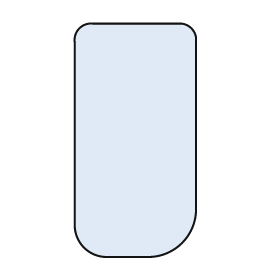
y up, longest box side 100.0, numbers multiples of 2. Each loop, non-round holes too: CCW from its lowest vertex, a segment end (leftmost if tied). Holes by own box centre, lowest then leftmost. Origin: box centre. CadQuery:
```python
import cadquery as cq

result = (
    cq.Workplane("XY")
    .moveTo(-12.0, -50.0)
    .lineTo(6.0, -50.0)
    .threePointArc((20.0, -44.0), (26.0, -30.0))
    .lineTo(26.0, 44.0)
    .threePointArc((24.0, 48.0), (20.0, 50.0))
    .lineTo(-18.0, 50.0)
    .threePointArc((-24.0, 48.0), (-26.0, 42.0))
    .lineTo(-26.0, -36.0)
    .threePointArc((-22.0, -46.0), (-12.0, -50.0))
    .close()
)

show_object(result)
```